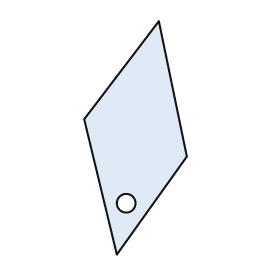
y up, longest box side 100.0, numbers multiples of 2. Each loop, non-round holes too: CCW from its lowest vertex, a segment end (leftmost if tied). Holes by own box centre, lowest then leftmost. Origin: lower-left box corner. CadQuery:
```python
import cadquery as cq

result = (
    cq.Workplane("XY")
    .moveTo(14.0, 0.0)
    .lineTo(44.0, 42.0)
    .lineTo(32.0, 100.0)
    .lineTo(0.0, 58.0)
    .close()
    .moveTo(18.0, 22.0)
    .circle(4.0)
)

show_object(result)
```